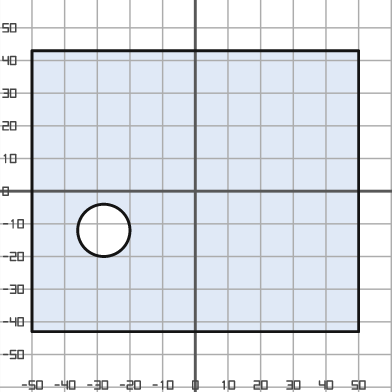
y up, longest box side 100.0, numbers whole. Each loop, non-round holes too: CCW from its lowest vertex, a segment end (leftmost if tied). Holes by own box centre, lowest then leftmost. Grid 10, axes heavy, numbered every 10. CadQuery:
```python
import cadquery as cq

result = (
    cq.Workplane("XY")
    .moveTo(-50.0, -43.0)
    .lineTo(50.0, -43.0)
    .lineTo(50.0, 43.0)
    .lineTo(-50.0, 43.0)
    .close()
    .moveTo(-28.0, -12.0)
    .circle(8.0)
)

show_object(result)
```